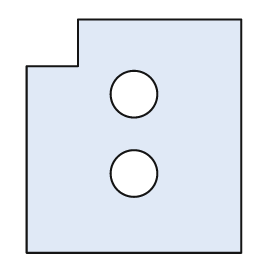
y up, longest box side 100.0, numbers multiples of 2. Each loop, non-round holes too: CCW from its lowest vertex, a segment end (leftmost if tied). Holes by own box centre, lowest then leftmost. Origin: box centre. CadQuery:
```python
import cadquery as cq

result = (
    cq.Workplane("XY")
    .moveTo(-46.0, -50.0)
    .lineTo(46.0, -50.0)
    .lineTo(46.0, 50.0)
    .lineTo(-24.0, 50.0)
    .lineTo(-24.0, 30.0)
    .lineTo(-46.0, 30.0)
    .close()
    .moveTo(0.0, -16.0)
    .circle(10.0)
    .moveTo(0.0, 18.0)
    .circle(10.0)
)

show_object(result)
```